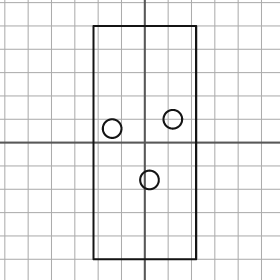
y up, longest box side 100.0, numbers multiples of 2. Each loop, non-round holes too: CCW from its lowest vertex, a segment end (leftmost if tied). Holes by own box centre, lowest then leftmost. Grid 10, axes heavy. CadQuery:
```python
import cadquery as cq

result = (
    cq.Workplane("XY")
    .moveTo(-22.0, -50.0)
    .lineTo(22.0, -50.0)
    .lineTo(22.0, 50.0)
    .lineTo(-22.0, 50.0)
    .close()
    .moveTo(2.0, -16.0)
    .circle(4.0)
    .moveTo(-14.0, 6.0)
    .circle(4.0)
    .moveTo(12.0, 10.0)
    .circle(4.0)
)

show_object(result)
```